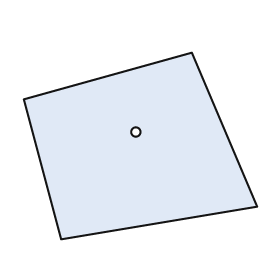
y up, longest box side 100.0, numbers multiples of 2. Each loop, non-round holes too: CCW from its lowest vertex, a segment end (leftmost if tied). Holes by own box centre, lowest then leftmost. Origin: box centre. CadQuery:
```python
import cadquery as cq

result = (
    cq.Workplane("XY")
    .moveTo(-34.0, -40.0)
    .lineTo(50.0, -26.0)
    .lineTo(22.0, 40.0)
    .lineTo(-50.0, 20.0)
    .close()
    .moveTo(-2.0, 6.0)
    .circle(2.0)
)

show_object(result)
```